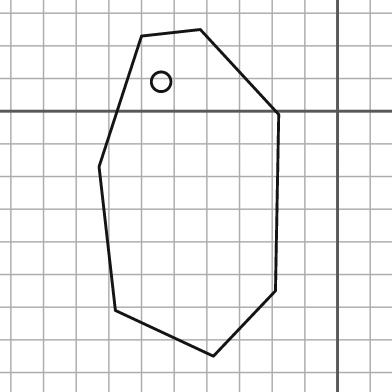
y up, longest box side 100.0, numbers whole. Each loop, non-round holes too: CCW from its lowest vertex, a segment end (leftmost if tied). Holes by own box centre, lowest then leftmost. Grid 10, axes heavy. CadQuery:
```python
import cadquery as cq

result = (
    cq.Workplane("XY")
    .moveTo(-38.0, -75.0)
    .lineTo(-19.0, -55.0)
    .lineTo(-18.0, -1.0)
    .lineTo(-42.0, 25.0)
    .lineTo(-60.0, 23.0)
    .lineTo(-73.0, -17.0)
    .lineTo(-68.0, -61.0)
    .close()
    .moveTo(-54.0, 9.0)
    .circle(3.0)
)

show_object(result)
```